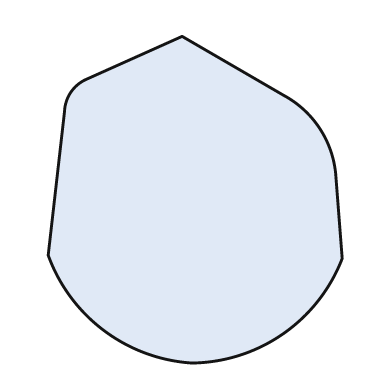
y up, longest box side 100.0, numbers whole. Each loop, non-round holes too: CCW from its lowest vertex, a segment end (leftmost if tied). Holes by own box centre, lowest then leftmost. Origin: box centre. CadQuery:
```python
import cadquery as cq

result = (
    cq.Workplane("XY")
    .moveTo(-1.0, -50.0)
    .threePointArc((27.0, -41.0), (45.0, -18.0))
    .lineTo(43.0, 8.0)
    .threePointArc((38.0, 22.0), (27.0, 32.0))
    .lineTo(-4.0, 50.0)
    .lineTo(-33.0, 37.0)
    .threePointArc((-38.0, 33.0), (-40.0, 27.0))
    .lineTo(-45.0, -17.0)
    .threePointArc((-28.0, -40.0), (-1.0, -50.0))
    .close()
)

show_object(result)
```